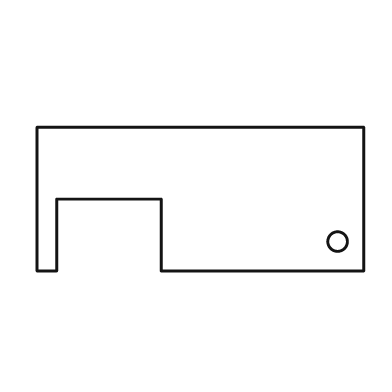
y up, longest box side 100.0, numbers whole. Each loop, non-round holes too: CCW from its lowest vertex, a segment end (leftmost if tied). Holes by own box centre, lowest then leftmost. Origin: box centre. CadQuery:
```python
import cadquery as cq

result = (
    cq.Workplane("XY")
    .moveTo(-50.0, -22.0)
    .lineTo(-44.0, -22.0)
    .lineTo(-44.0, 0.0)
    .lineTo(-12.0, 0.0)
    .lineTo(-12.0, -22.0)
    .lineTo(50.0, -22.0)
    .lineTo(50.0, 22.0)
    .lineTo(-50.0, 22.0)
    .close()
    .moveTo(42.0, -13.0)
    .circle(3.0)
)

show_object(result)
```